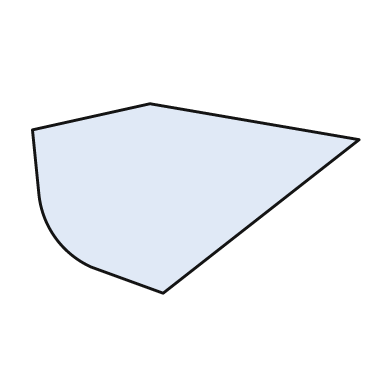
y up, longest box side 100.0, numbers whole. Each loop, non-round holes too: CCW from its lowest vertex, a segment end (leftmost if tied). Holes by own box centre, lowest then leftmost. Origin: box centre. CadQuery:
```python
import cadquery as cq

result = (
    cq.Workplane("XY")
    .moveTo(-10.0, -29.0)
    .lineTo(50.0, 18.0)
    .lineTo(-14.0, 29.0)
    .lineTo(-50.0, 21.0)
    .lineTo(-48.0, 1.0)
    .threePointArc((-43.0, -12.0), (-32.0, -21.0))
    .close()
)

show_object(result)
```